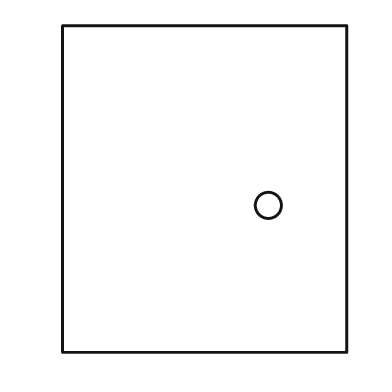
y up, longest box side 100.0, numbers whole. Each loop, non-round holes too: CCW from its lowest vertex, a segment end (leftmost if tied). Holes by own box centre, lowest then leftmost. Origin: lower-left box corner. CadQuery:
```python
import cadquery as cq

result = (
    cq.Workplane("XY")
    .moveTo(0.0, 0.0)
    .lineTo(87.0, 0.0)
    .lineTo(87.0, 100.0)
    .lineTo(0.0, 100.0)
    .close()
    .moveTo(63.0, 45.0)
    .circle(4.0)
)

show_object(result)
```